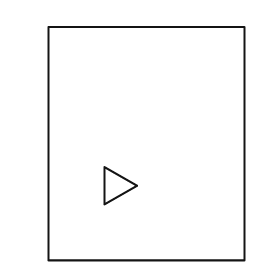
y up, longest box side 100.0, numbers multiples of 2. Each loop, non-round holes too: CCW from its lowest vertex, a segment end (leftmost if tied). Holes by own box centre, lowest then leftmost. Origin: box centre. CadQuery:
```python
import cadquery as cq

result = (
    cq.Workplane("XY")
    .moveTo(-42.0, -50.0)
    .lineTo(42.0, -50.0)
    .lineTo(42.0, 50.0)
    .lineTo(-42.0, 50.0)
    .close()
    .moveTo(-18.0, -26.0)
    .lineTo(-4.0, -18.0)
    .lineTo(-18.0, -10.0)
    .close()
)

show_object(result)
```